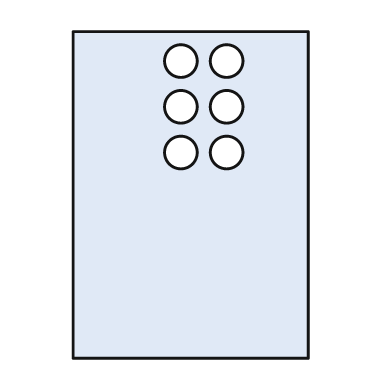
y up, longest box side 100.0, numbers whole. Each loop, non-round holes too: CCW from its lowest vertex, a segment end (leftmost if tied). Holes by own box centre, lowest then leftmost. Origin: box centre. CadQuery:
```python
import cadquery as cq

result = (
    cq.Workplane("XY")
    .moveTo(-36.0, -50.0)
    .lineTo(36.0, -50.0)
    .lineTo(36.0, 50.0)
    .lineTo(-36.0, 50.0)
    .close()
    .moveTo(-3.0, 13.0)
    .circle(5.0)
    .moveTo(11.0, 13.0)
    .circle(5.0)
    .moveTo(-3.0, 27.0)
    .circle(5.0)
    .moveTo(11.0, 27.0)
    .circle(5.0)
    .moveTo(-3.0, 41.0)
    .circle(5.0)
    .moveTo(11.0, 41.0)
    .circle(5.0)
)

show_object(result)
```